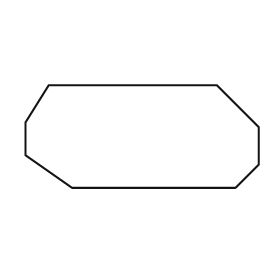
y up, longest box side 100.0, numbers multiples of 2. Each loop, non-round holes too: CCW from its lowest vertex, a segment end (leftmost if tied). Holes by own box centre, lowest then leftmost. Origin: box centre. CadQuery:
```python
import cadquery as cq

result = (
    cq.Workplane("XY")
    .moveTo(-30.0, -22.0)
    .lineTo(40.0, -22.0)
    .lineTo(50.0, -12.0)
    .lineTo(50.0, 4.0)
    .lineTo(32.0, 22.0)
    .lineTo(-40.0, 22.0)
    .lineTo(-50.0, 6.0)
    .lineTo(-50.0, -8.0)
    .close()
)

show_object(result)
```